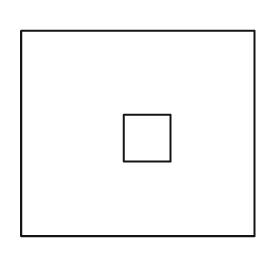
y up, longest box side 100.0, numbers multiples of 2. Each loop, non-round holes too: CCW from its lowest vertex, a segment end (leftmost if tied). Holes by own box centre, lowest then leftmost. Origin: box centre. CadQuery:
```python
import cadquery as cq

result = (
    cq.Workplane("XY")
    .moveTo(-50.0, -44.0)
    .lineTo(50.0, -44.0)
    .lineTo(50.0, 44.0)
    .lineTo(-50.0, 44.0)
    .close()
    .moveTo(-6.0, -12.0)
    .lineTo(14.0, -12.0)
    .lineTo(14.0, 8.0)
    .lineTo(-6.0, 8.0)
    .close()
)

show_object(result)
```